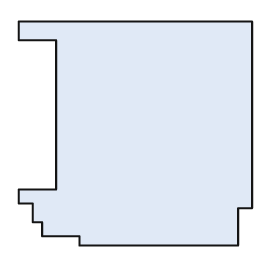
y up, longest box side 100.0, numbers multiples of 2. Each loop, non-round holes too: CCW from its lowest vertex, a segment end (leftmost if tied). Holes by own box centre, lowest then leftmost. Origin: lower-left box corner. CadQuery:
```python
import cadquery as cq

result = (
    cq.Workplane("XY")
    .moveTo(26.0, 0.0)
    .lineTo(94.0, 0.0)
    .lineTo(94.0, 16.0)
    .lineTo(100.0, 16.0)
    .lineTo(100.0, 96.0)
    .lineTo(0.0, 96.0)
    .lineTo(0.0, 88.0)
    .lineTo(16.0, 88.0)
    .lineTo(16.0, 24.0)
    .lineTo(0.0, 24.0)
    .lineTo(0.0, 18.0)
    .lineTo(6.0, 18.0)
    .lineTo(6.0, 10.0)
    .lineTo(10.0, 10.0)
    .lineTo(10.0, 4.0)
    .lineTo(26.0, 4.0)
    .close()
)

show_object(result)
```